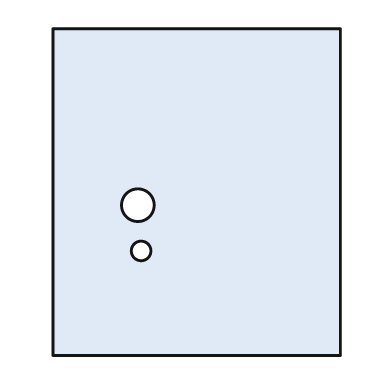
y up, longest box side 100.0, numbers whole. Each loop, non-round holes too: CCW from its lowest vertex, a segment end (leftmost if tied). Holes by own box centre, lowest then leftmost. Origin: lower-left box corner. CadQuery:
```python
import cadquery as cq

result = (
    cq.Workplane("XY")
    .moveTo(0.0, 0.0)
    .lineTo(88.0, 0.0)
    .lineTo(88.0, 100.0)
    .lineTo(0.0, 100.0)
    .close()
    .moveTo(27.0, 32.0)
    .circle(3.0)
    .moveTo(26.0, 46.0)
    .circle(5.0)
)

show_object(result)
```